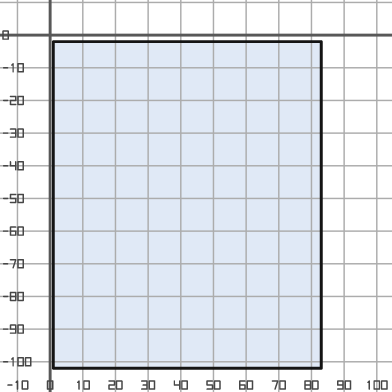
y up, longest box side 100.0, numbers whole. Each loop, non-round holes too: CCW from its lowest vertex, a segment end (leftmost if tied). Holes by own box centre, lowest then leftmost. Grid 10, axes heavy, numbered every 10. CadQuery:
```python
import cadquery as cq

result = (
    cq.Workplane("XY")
    .moveTo(1.0, -102.0)
    .lineTo(83.0, -102.0)
    .lineTo(83.0, -2.0)
    .lineTo(1.0, -2.0)
    .close()
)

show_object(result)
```